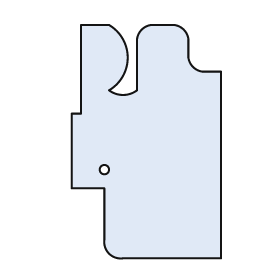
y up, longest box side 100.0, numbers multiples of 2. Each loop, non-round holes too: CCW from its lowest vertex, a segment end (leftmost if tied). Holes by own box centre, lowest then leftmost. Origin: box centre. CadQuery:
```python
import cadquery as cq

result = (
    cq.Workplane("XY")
    .moveTo(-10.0, -50.0)
    .lineTo(32.0, -50.0)
    .lineTo(32.0, 30.0)
    .lineTo(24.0, 30.0)
    .threePointArc((20.0, 32.0), (18.0, 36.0))
    .lineTo(18.0, 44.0)
    .threePointArc((16.0, 48.0), (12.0, 50.0))
    .lineTo(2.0, 50.0)
    .threePointArc((-2.0, 48.0), (-4.0, 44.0))
    .lineTo(-4.0, 22.0)
    .threePointArc((-10.0, 20.0), (-16.0, 22.0))
    .threePointArc((-8.0, 36.0), (-16.0, 50.0))
    .lineTo(-28.0, 50.0)
    .lineTo(-28.0, 12.0)
    .lineTo(-32.0, 12.0)
    .lineTo(-32.0, -20.0)
    .lineTo(-18.0, -20.0)
    .lineTo(-18.0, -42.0)
    .threePointArc((-16.0, -48.0), (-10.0, -50.0))
    .close()
    .moveTo(-18.0, -12.0)
    .circle(2.0)
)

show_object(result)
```